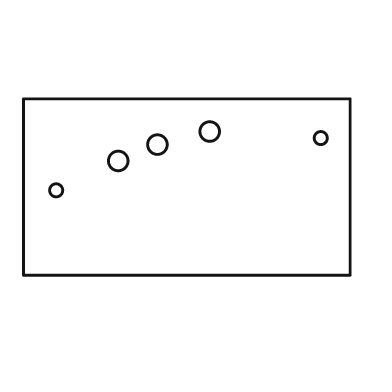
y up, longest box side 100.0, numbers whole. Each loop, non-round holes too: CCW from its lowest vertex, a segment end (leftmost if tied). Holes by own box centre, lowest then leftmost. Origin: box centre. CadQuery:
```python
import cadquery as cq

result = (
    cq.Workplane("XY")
    .moveTo(-50.0, -27.0)
    .lineTo(50.0, -27.0)
    .lineTo(50.0, 27.0)
    .lineTo(-50.0, 27.0)
    .close()
    .moveTo(-40.0, -1.0)
    .circle(2.0)
    .moveTo(-21.0, 8.0)
    .circle(3.0)
    .moveTo(-9.0, 13.0)
    .circle(3.0)
    .moveTo(41.0, 15.0)
    .circle(2.0)
    .moveTo(7.0, 17.0)
    .circle(3.0)
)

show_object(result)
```